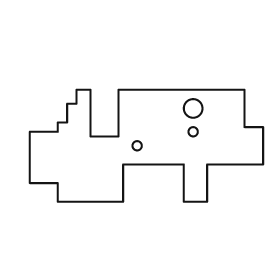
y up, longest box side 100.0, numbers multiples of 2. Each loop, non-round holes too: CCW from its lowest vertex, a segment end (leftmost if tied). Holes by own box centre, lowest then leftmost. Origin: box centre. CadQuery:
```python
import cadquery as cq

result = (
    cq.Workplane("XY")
    .moveTo(-38.0, -24.0)
    .lineTo(-10.0, -24.0)
    .lineTo(-10.0, -8.0)
    .lineTo(16.0, -8.0)
    .lineTo(16.0, -24.0)
    .lineTo(26.0, -24.0)
    .lineTo(26.0, -8.0)
    .lineTo(50.0, -8.0)
    .lineTo(50.0, 8.0)
    .lineTo(42.0, 8.0)
    .lineTo(42.0, 24.0)
    .lineTo(-12.0, 24.0)
    .lineTo(-12.0, 4.0)
    .lineTo(-24.0, 4.0)
    .lineTo(-24.0, 24.0)
    .lineTo(-30.0, 24.0)
    .lineTo(-30.0, 18.0)
    .lineTo(-34.0, 18.0)
    .lineTo(-34.0, 10.0)
    .lineTo(-38.0, 10.0)
    .lineTo(-38.0, 6.0)
    .lineTo(-50.0, 6.0)
    .lineTo(-50.0, -16.0)
    .lineTo(-38.0, -16.0)
    .close()
    .moveTo(-4.0, 0.0)
    .circle(2.0)
    .moveTo(20.0, 6.0)
    .circle(2.0)
    .moveTo(20.0, 16.0)
    .circle(4.0)
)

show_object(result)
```